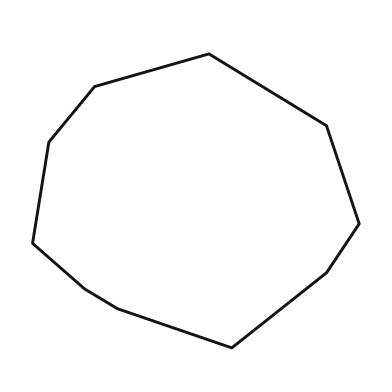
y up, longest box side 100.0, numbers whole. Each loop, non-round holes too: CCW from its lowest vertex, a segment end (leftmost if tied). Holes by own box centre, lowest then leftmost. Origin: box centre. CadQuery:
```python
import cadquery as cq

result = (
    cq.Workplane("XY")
    .moveTo(11.0, -45.0)
    .lineTo(40.0, -22.0)
    .lineTo(50.0, -7.0)
    .lineTo(40.0, 23.0)
    .lineTo(4.0, 45.0)
    .lineTo(-31.0, 35.0)
    .lineTo(-45.0, 18.0)
    .lineTo(-50.0, -13.0)
    .lineTo(-34.0, -27.0)
    .lineTo(-24.0, -33.0)
    .close()
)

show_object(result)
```